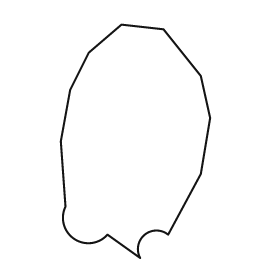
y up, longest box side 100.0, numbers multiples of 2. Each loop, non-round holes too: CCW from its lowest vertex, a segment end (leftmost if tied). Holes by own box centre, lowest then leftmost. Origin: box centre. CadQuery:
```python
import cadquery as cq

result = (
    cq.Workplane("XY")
    .moveTo(2.0, -50.0)
    .threePointArc((4.0, -40.0), (14.0, -40.0))
    .lineTo(28.0, -14.0)
    .lineTo(32.0, 10.0)
    .lineTo(28.0, 28.0)
    .lineTo(12.0, 48.0)
    .lineTo(-6.0, 50.0)
    .lineTo(-20.0, 38.0)
    .lineTo(-28.0, 22.0)
    .lineTo(-32.0, 0.0)
    .lineTo(-30.0, -28.0)
    .threePointArc((-26.0, -42.0), (-12.0, -40.0))
    .close()
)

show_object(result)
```